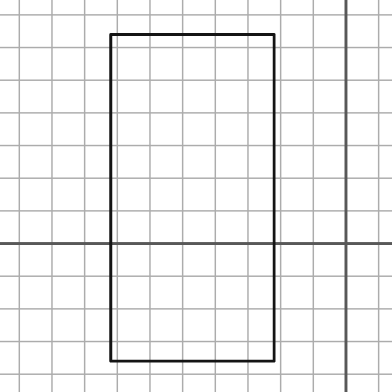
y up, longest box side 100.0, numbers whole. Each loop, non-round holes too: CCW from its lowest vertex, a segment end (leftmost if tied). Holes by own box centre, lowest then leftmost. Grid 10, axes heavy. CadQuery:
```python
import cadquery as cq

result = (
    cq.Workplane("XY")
    .moveTo(-72.0, -36.0)
    .lineTo(-22.0, -36.0)
    .lineTo(-22.0, 64.0)
    .lineTo(-72.0, 64.0)
    .close()
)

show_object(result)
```